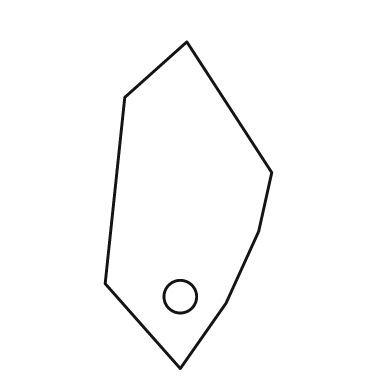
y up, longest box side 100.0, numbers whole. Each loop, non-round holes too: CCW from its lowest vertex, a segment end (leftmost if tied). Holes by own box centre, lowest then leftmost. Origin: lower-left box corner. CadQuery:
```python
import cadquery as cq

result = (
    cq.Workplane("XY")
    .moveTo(23.0, 0.0)
    .lineTo(37.0, 20.0)
    .lineTo(47.0, 42.0)
    .lineTo(51.0, 60.0)
    .lineTo(25.0, 100.0)
    .lineTo(6.0, 83.0)
    .lineTo(0.0, 26.0)
    .close()
    .moveTo(23.0, 22.0)
    .circle(5.0)
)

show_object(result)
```